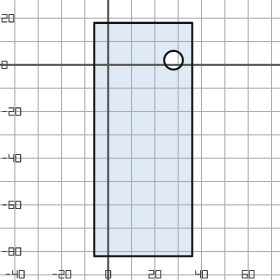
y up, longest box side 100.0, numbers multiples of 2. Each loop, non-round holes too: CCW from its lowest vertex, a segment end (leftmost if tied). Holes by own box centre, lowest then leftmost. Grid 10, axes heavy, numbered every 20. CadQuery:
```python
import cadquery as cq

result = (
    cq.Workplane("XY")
    .moveTo(-6.0, -82.0)
    .lineTo(36.0, -82.0)
    .lineTo(36.0, 18.0)
    .lineTo(-6.0, 18.0)
    .close()
    .moveTo(28.0, 2.0)
    .circle(4.0)
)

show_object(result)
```